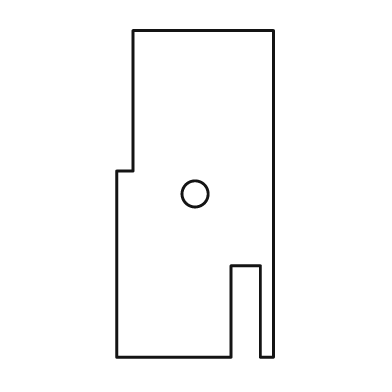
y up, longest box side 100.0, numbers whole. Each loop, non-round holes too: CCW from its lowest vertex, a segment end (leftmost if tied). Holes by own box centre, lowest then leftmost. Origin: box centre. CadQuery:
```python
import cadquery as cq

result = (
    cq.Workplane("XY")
    .moveTo(-24.0, -50.0)
    .lineTo(11.0, -50.0)
    .lineTo(11.0, -22.0)
    .lineTo(20.0, -22.0)
    .lineTo(20.0, -50.0)
    .lineTo(24.0, -50.0)
    .lineTo(24.0, 50.0)
    .lineTo(-19.0, 50.0)
    .lineTo(-19.0, 7.0)
    .lineTo(-24.0, 7.0)
    .close()
    .moveTo(0.0, 0.0)
    .circle(4.0)
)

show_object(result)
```